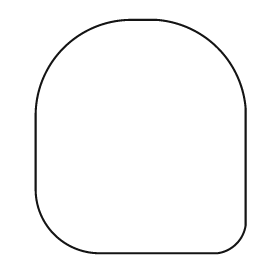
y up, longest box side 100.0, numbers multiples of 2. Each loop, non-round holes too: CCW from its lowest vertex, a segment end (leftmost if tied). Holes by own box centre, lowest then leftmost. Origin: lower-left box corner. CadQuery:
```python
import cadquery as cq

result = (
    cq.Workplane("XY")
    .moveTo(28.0, 0.0)
    .lineTo(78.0, 0.0)
    .threePointArc((86.0, 4.0), (90.0, 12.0))
    .lineTo(90.0, 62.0)
    .threePointArc((78.0, 88.0), (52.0, 100.0))
    .lineTo(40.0, 100.0)
    .threePointArc((12.0, 88.0), (0.0, 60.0))
    .lineTo(0.0, 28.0)
    .threePointArc((8.0, 8.0), (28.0, 0.0))
    .close()
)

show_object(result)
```